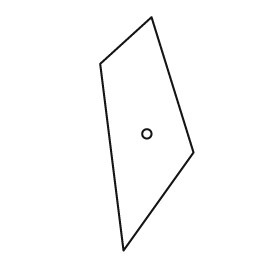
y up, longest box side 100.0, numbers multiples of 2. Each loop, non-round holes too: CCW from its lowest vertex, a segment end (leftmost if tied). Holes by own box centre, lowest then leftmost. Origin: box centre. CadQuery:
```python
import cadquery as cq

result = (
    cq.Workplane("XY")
    .moveTo(-10.0, -50.0)
    .lineTo(20.0, -8.0)
    .lineTo(2.0, 50.0)
    .lineTo(-20.0, 30.0)
    .close()
    .moveTo(0.0, 0.0)
    .circle(2.0)
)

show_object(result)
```